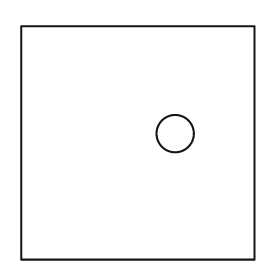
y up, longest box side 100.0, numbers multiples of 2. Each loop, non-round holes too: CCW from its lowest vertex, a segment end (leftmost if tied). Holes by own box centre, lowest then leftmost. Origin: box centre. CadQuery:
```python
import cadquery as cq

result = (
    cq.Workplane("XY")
    .moveTo(-50.0, -50.0)
    .lineTo(50.0, -50.0)
    .lineTo(50.0, 50.0)
    .lineTo(-50.0, 50.0)
    .close()
    .moveTo(16.0, 4.0)
    .circle(8.0)
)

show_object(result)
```